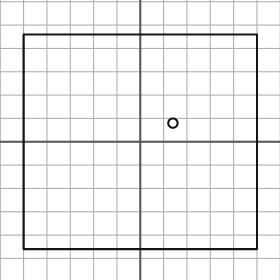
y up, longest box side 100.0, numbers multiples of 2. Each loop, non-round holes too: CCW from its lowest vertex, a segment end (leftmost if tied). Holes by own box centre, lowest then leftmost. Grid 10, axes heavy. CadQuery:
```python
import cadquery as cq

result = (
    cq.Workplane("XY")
    .moveTo(-50.0, -46.0)
    .lineTo(50.0, -46.0)
    .lineTo(50.0, 46.0)
    .lineTo(-50.0, 46.0)
    .close()
    .moveTo(14.0, 8.0)
    .circle(2.0)
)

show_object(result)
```